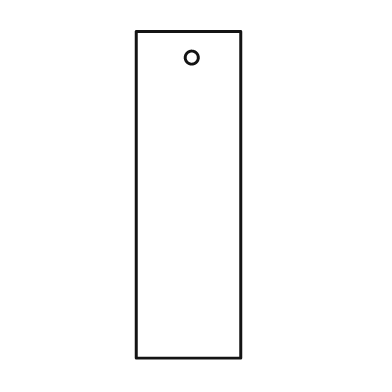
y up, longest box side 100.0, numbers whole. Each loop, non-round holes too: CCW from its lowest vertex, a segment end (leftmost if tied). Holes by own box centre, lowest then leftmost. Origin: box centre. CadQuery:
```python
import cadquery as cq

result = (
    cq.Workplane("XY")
    .moveTo(-16.0, -50.0)
    .lineTo(16.0, -50.0)
    .lineTo(16.0, 50.0)
    .lineTo(-16.0, 50.0)
    .close()
    .moveTo(1.0, 42.0)
    .circle(2.0)
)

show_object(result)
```